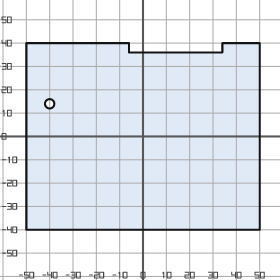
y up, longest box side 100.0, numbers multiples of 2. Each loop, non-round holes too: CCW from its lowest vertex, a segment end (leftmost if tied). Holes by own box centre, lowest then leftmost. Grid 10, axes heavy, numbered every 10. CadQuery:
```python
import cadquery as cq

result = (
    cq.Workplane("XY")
    .moveTo(-50.0, -40.0)
    .lineTo(50.0, -40.0)
    .lineTo(50.0, 40.0)
    .lineTo(34.0, 40.0)
    .lineTo(34.0, 36.0)
    .lineTo(-6.0, 36.0)
    .lineTo(-6.0, 40.0)
    .lineTo(-50.0, 40.0)
    .close()
    .moveTo(-40.0, 14.0)
    .circle(2.0)
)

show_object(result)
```